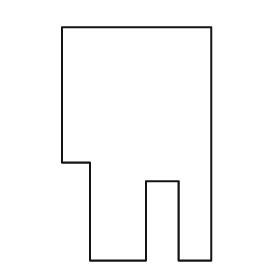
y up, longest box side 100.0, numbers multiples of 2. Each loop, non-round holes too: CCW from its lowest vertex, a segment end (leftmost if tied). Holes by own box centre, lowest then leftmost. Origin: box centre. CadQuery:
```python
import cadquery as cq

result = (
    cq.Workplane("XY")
    .moveTo(-20.0, -50.0)
    .lineTo(4.0, -50.0)
    .lineTo(4.0, -16.0)
    .lineTo(18.0, -16.0)
    .lineTo(18.0, -50.0)
    .lineTo(32.0, -50.0)
    .lineTo(32.0, 50.0)
    .lineTo(-32.0, 50.0)
    .lineTo(-32.0, -8.0)
    .lineTo(-20.0, -8.0)
    .close()
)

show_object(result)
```